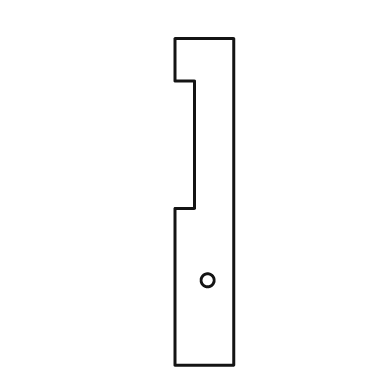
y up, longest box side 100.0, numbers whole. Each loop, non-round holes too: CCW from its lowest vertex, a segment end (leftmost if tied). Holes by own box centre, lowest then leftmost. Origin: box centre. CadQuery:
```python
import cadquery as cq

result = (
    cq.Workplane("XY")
    .moveTo(-9.0, -50.0)
    .lineTo(9.0, -50.0)
    .lineTo(9.0, 50.0)
    .lineTo(-9.0, 50.0)
    .lineTo(-9.0, 37.0)
    .lineTo(-3.0, 37.0)
    .lineTo(-3.0, -2.0)
    .lineTo(-9.0, -2.0)
    .close()
    .moveTo(1.0, -24.0)
    .circle(2.0)
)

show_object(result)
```